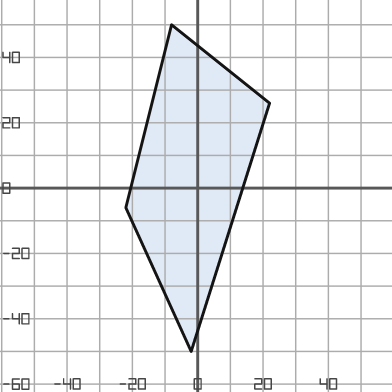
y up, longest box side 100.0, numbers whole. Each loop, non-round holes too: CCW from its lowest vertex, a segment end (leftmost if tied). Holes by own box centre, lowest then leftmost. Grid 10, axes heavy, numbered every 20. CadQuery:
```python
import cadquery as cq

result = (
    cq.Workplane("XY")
    .moveTo(-2.0, -50.0)
    .lineTo(22.0, 26.0)
    .lineTo(-8.0, 50.0)
    .lineTo(-22.0, -6.0)
    .close()
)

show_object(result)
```